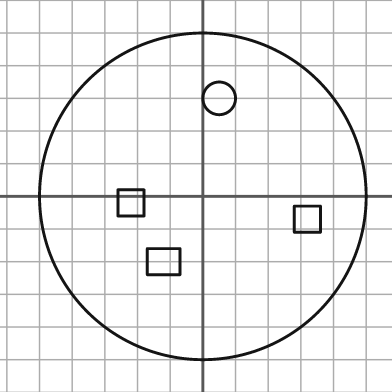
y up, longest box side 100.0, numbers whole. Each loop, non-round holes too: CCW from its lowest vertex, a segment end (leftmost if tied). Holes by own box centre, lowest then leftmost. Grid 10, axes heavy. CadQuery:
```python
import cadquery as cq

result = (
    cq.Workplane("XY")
    .moveTo(0.0, 0.0)
    .circle(50.0)
    .moveTo(-17.0, -24.0)
    .lineTo(-7.0, -24.0)
    .lineTo(-7.0, -16.0)
    .lineTo(-17.0, -16.0)
    .close()
    .moveTo(28.0, -11.0)
    .lineTo(36.0, -11.0)
    .lineTo(36.0, -3.0)
    .lineTo(28.0, -3.0)
    .close()
    .moveTo(-26.0, -6.0)
    .lineTo(-18.0, -6.0)
    .lineTo(-18.0, 2.0)
    .lineTo(-26.0, 2.0)
    .close()
    .moveTo(5.0, 30.0)
    .circle(5.0)
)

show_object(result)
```